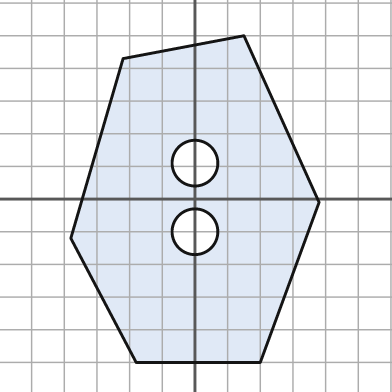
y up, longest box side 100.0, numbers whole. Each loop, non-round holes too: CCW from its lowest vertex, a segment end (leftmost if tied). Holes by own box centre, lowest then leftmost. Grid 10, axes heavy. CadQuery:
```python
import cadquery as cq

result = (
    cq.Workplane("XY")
    .moveTo(-18.0, -50.0)
    .lineTo(20.0, -50.0)
    .lineTo(38.0, -1.0)
    .lineTo(15.0, 50.0)
    .lineTo(-22.0, 43.0)
    .lineTo(-38.0, -12.0)
    .close()
    .moveTo(0.0, -10.0)
    .circle(7.0)
    .moveTo(0.0, 11.0)
    .circle(7.0)
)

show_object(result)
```